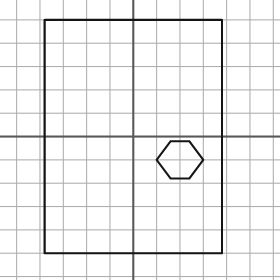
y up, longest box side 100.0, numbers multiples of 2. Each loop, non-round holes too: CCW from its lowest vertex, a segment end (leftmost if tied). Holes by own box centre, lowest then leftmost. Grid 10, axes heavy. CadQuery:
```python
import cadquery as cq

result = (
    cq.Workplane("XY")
    .moveTo(-38.0, -50.0)
    .lineTo(38.0, -50.0)
    .lineTo(38.0, 50.0)
    .lineTo(-38.0, 50.0)
    .close()
    .moveTo(16.0, -18.0)
    .lineTo(24.0, -18.0)
    .lineTo(30.0, -10.0)
    .lineTo(24.0, -2.0)
    .lineTo(16.0, -2.0)
    .lineTo(10.0, -10.0)
    .close()
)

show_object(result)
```